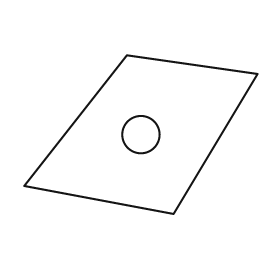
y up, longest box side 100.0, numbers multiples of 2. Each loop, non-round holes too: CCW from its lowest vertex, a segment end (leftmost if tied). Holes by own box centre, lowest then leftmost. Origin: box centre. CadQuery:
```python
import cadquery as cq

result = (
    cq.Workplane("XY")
    .moveTo(14.0, -34.0)
    .lineTo(50.0, 26.0)
    .lineTo(-6.0, 34.0)
    .lineTo(-50.0, -22.0)
    .close()
    .moveTo(0.0, 0.0)
    .circle(8.0)
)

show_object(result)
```